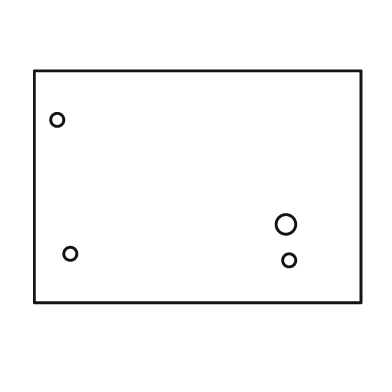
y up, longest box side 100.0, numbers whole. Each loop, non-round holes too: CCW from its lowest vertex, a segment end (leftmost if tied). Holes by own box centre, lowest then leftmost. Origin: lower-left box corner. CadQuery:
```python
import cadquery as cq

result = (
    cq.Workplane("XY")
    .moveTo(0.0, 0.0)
    .lineTo(100.0, 0.0)
    .lineTo(100.0, 71.0)
    .lineTo(0.0, 71.0)
    .close()
    .moveTo(78.0, 13.0)
    .circle(2.0)
    .moveTo(11.0, 15.0)
    .circle(2.0)
    .moveTo(77.0, 24.0)
    .circle(3.0)
    .moveTo(7.0, 56.0)
    .circle(2.0)
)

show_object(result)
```